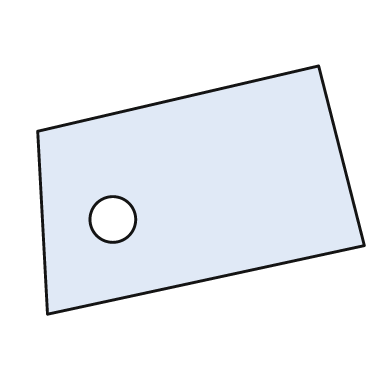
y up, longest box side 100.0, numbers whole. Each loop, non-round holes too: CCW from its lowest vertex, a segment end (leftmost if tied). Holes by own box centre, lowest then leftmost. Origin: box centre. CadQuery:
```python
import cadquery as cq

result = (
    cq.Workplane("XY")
    .moveTo(-47.0, -38.0)
    .lineTo(50.0, -17.0)
    .lineTo(36.0, 38.0)
    .lineTo(-50.0, 18.0)
    .close()
    .moveTo(-27.0, -9.0)
    .circle(7.0)
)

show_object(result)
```